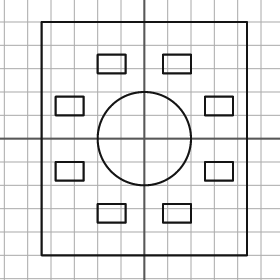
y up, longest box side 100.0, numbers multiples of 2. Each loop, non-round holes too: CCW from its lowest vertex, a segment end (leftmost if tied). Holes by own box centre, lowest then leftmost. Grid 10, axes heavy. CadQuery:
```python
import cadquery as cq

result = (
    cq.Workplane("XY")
    .moveTo(-44.0, -50.0)
    .lineTo(44.0, -50.0)
    .lineTo(44.0, 50.0)
    .lineTo(-44.0, 50.0)
    .close()
    .moveTo(-20.0, -36.0)
    .lineTo(-8.0, -36.0)
    .lineTo(-8.0, -28.0)
    .lineTo(-20.0, -28.0)
    .close()
    .moveTo(8.0, -36.0)
    .lineTo(20.0, -36.0)
    .lineTo(20.0, -28.0)
    .lineTo(8.0, -28.0)
    .close()
    .moveTo(-38.0, -18.0)
    .lineTo(-26.0, -18.0)
    .lineTo(-26.0, -10.0)
    .lineTo(-38.0, -10.0)
    .close()
    .moveTo(26.0, -18.0)
    .lineTo(38.0, -18.0)
    .lineTo(38.0, -10.0)
    .lineTo(26.0, -10.0)
    .close()
    .moveTo(0.0, 0.0)
    .circle(20.0)
    .moveTo(-38.0, 10.0)
    .lineTo(-26.0, 10.0)
    .lineTo(-26.0, 18.0)
    .lineTo(-38.0, 18.0)
    .close()
    .moveTo(26.0, 10.0)
    .lineTo(38.0, 10.0)
    .lineTo(38.0, 18.0)
    .lineTo(26.0, 18.0)
    .close()
    .moveTo(-20.0, 28.0)
    .lineTo(-8.0, 28.0)
    .lineTo(-8.0, 36.0)
    .lineTo(-20.0, 36.0)
    .close()
    .moveTo(8.0, 28.0)
    .lineTo(20.0, 28.0)
    .lineTo(20.0, 36.0)
    .lineTo(8.0, 36.0)
    .close()
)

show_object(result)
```